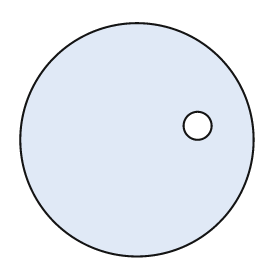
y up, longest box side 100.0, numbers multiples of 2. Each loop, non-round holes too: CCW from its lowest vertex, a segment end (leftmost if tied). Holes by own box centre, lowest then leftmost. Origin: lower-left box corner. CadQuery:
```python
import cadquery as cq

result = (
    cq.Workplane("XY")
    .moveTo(50.0, 50.0)
    .circle(50.0)
    .moveTo(76.0, 56.0)
    .circle(6.0)
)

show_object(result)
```